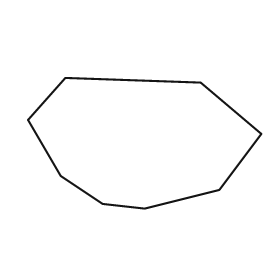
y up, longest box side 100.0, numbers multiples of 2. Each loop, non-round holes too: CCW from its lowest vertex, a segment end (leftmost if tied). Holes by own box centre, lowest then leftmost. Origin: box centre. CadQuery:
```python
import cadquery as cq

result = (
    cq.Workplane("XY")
    .moveTo(0.0, -28.0)
    .lineTo(32.0, -20.0)
    .lineTo(50.0, 4.0)
    .lineTo(24.0, 26.0)
    .lineTo(-34.0, 28.0)
    .lineTo(-50.0, 10.0)
    .lineTo(-36.0, -14.0)
    .lineTo(-18.0, -26.0)
    .close()
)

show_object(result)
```